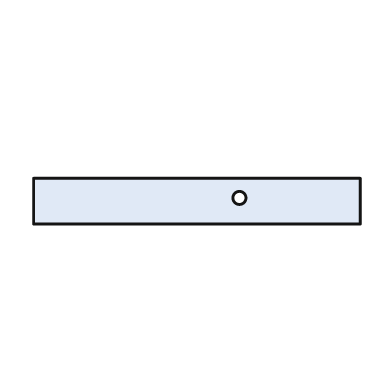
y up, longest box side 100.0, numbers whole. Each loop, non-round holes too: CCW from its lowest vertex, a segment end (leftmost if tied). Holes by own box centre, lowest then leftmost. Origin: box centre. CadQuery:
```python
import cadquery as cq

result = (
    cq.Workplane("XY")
    .moveTo(-50.0, -7.0)
    .lineTo(50.0, -7.0)
    .lineTo(50.0, 7.0)
    .lineTo(-50.0, 7.0)
    .close()
    .moveTo(13.0, 1.0)
    .circle(2.0)
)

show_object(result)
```